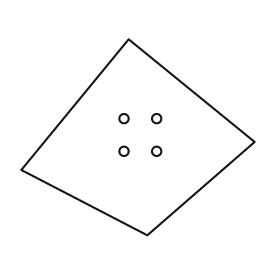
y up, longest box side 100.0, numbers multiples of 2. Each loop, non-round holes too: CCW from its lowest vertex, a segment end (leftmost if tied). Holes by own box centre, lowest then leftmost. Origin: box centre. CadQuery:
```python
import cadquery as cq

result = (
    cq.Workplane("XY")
    .moveTo(4.0, -42.0)
    .lineTo(50.0, -2.0)
    .lineTo(-4.0, 42.0)
    .lineTo(-50.0, -14.0)
    .close()
    .moveTo(-6.0, -6.0)
    .circle(2.0)
    .moveTo(8.0, -6.0)
    .circle(2.0)
    .moveTo(-6.0, 8.0)
    .circle(2.0)
    .moveTo(8.0, 8.0)
    .circle(2.0)
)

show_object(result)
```